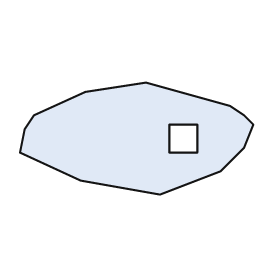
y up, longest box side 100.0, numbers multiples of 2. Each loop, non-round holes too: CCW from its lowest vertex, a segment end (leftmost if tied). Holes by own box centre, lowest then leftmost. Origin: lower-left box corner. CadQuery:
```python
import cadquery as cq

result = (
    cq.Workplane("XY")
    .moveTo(60.0, 0.0)
    .lineTo(86.0, 10.0)
    .lineTo(96.0, 20.0)
    .lineTo(100.0, 30.0)
    .lineTo(96.0, 34.0)
    .lineTo(90.0, 38.0)
    .lineTo(54.0, 48.0)
    .lineTo(28.0, 44.0)
    .lineTo(6.0, 34.0)
    .lineTo(2.0, 28.0)
    .lineTo(0.0, 18.0)
    .lineTo(26.0, 6.0)
    .close()
    .moveTo(64.0, 18.0)
    .lineTo(76.0, 18.0)
    .lineTo(76.0, 30.0)
    .lineTo(64.0, 30.0)
    .close()
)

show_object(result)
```